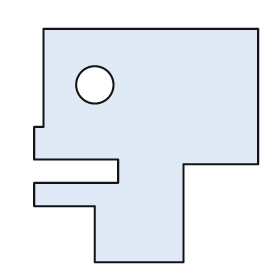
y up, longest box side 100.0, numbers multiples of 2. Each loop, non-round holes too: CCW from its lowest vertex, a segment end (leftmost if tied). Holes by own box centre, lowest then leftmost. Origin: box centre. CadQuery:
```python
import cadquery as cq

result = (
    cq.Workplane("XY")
    .moveTo(-22.0, -50.0)
    .lineTo(16.0, -50.0)
    .lineTo(16.0, -8.0)
    .lineTo(48.0, -8.0)
    .lineTo(48.0, 50.0)
    .lineTo(-44.0, 50.0)
    .lineTo(-44.0, 8.0)
    .lineTo(-48.0, 8.0)
    .lineTo(-48.0, -6.0)
    .lineTo(-12.0, -6.0)
    .lineTo(-12.0, -16.0)
    .lineTo(-48.0, -16.0)
    .lineTo(-48.0, -26.0)
    .lineTo(-22.0, -26.0)
    .close()
    .moveTo(-22.0, 26.0)
    .circle(8.0)
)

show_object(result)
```